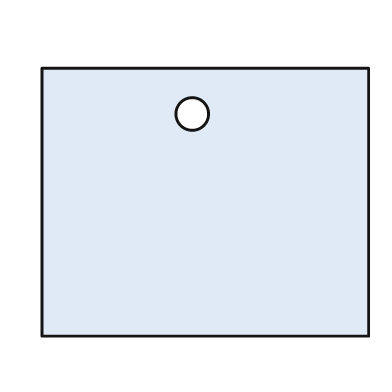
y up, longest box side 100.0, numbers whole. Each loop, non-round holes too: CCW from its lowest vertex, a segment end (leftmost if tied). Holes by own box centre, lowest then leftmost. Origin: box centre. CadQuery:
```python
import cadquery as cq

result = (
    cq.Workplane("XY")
    .moveTo(-50.0, -41.0)
    .lineTo(50.0, -41.0)
    .lineTo(50.0, 41.0)
    .lineTo(-50.0, 41.0)
    .close()
    .moveTo(-4.0, 27.0)
    .circle(5.0)
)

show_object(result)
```